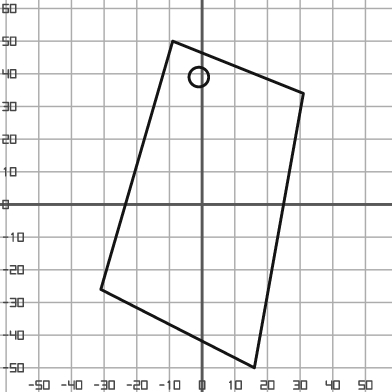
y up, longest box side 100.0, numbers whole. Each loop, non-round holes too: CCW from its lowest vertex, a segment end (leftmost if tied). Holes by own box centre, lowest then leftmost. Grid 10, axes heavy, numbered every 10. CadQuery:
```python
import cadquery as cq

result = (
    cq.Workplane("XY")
    .moveTo(16.0, -50.0)
    .lineTo(31.0, 34.0)
    .lineTo(-9.0, 50.0)
    .lineTo(-31.0, -26.0)
    .close()
    .moveTo(-1.0, 39.0)
    .circle(3.0)
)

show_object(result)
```